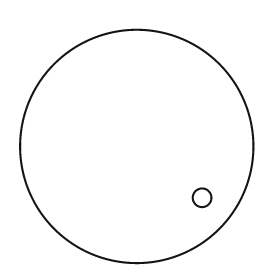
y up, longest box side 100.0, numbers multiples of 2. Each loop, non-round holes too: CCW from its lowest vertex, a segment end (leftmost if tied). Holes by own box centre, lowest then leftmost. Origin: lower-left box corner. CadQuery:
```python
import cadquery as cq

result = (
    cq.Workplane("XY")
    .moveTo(50.0, 50.0)
    .circle(50.0)
    .moveTo(78.0, 28.0)
    .circle(4.0)
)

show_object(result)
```